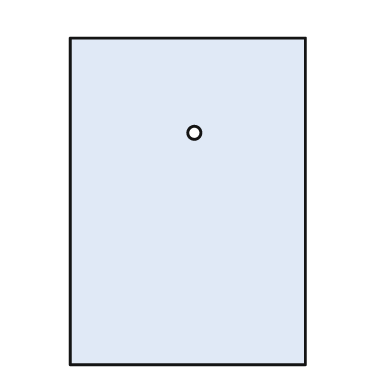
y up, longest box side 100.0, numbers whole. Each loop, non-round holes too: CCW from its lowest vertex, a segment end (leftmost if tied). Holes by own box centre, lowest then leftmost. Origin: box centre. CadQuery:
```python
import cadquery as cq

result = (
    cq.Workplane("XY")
    .moveTo(-36.0, -50.0)
    .lineTo(36.0, -50.0)
    .lineTo(36.0, 50.0)
    .lineTo(-36.0, 50.0)
    .close()
    .moveTo(2.0, 21.0)
    .circle(2.0)
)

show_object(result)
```